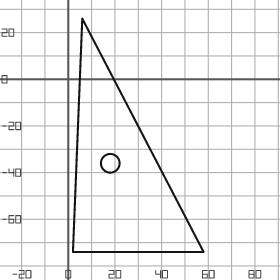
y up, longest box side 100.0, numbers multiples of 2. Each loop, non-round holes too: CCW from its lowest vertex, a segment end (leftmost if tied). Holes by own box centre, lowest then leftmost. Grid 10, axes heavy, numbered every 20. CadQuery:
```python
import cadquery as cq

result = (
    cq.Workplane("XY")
    .moveTo(2.0, -74.0)
    .lineTo(58.0, -74.0)
    .lineTo(6.0, 26.0)
    .close()
    .moveTo(18.0, -36.0)
    .circle(4.0)
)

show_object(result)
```